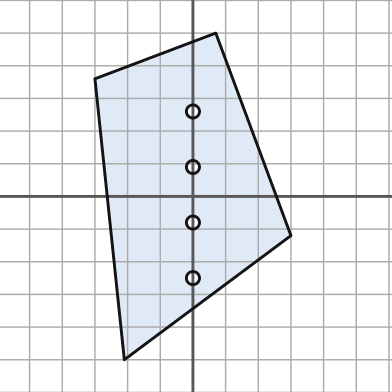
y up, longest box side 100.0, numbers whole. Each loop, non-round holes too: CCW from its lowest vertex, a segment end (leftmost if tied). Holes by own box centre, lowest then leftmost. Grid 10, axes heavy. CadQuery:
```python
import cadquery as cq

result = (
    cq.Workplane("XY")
    .moveTo(-21.0, -50.0)
    .lineTo(30.0, -12.0)
    .lineTo(7.0, 50.0)
    .lineTo(-30.0, 36.0)
    .close()
    .moveTo(0.0, -25.0)
    .circle(2.0)
    .moveTo(0.0, -8.0)
    .circle(2.0)
    .moveTo(0.0, 9.0)
    .circle(2.0)
    .moveTo(0.0, 26.0)
    .circle(2.0)
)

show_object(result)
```